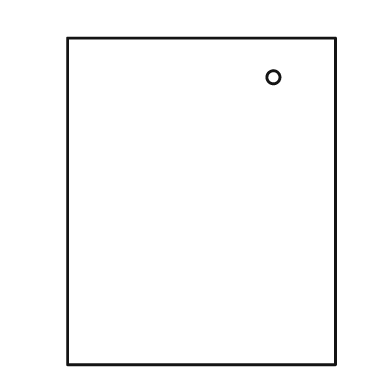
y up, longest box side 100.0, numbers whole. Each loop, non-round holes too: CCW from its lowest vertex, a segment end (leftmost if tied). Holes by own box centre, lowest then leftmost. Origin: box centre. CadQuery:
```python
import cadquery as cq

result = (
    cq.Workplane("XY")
    .moveTo(-41.0, -50.0)
    .lineTo(41.0, -50.0)
    .lineTo(41.0, 50.0)
    .lineTo(-41.0, 50.0)
    .close()
    .moveTo(22.0, 38.0)
    .circle(2.0)
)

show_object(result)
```